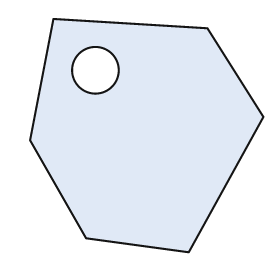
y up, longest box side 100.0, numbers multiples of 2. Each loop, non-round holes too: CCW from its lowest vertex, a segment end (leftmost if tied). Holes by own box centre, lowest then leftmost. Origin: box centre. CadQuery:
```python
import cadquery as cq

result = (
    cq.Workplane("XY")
    .moveTo(18.0, -50.0)
    .lineTo(50.0, 8.0)
    .lineTo(26.0, 46.0)
    .lineTo(-40.0, 50.0)
    .lineTo(-50.0, -2.0)
    .lineTo(-26.0, -44.0)
    .close()
    .moveTo(-22.0, 28.0)
    .circle(10.0)
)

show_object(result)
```